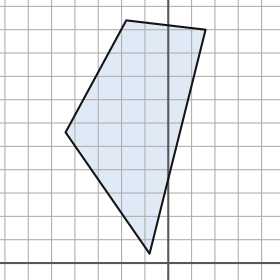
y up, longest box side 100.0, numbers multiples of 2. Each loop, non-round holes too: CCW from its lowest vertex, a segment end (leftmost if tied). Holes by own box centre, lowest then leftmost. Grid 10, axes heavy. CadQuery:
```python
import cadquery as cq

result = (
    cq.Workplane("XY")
    .moveTo(-8.0, 4.0)
    .lineTo(16.0, 100.0)
    .lineTo(-18.0, 104.0)
    .lineTo(-44.0, 56.0)
    .close()
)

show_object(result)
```